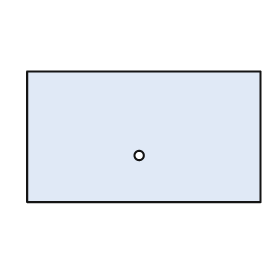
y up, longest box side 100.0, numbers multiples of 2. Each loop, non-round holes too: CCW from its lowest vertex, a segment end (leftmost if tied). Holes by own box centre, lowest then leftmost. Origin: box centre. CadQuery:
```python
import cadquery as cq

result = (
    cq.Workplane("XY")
    .moveTo(-50.0, -28.0)
    .lineTo(50.0, -28.0)
    .lineTo(50.0, 28.0)
    .lineTo(-50.0, 28.0)
    .close()
    .moveTo(-2.0, -8.0)
    .circle(2.0)
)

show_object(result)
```